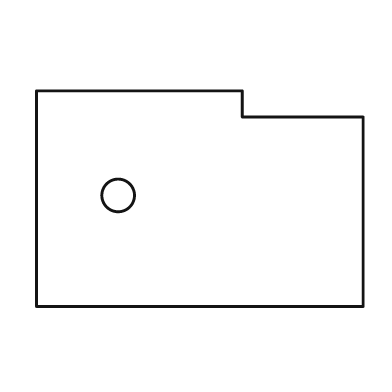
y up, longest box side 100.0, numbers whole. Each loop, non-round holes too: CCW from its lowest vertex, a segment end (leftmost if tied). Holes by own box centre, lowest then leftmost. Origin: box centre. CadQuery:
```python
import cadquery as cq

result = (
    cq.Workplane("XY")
    .moveTo(-50.0, -33.0)
    .lineTo(50.0, -33.0)
    .lineTo(50.0, 25.0)
    .lineTo(13.0, 25.0)
    .lineTo(13.0, 33.0)
    .lineTo(-50.0, 33.0)
    .close()
    .moveTo(-25.0, 1.0)
    .circle(5.0)
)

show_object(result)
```